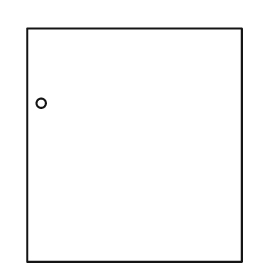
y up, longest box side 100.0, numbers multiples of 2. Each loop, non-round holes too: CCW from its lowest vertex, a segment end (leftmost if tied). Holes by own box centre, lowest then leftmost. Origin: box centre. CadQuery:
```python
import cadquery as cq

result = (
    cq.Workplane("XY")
    .moveTo(-46.0, -50.0)
    .lineTo(46.0, -50.0)
    .lineTo(46.0, 50.0)
    .lineTo(-46.0, 50.0)
    .close()
    .moveTo(-40.0, 18.0)
    .circle(2.0)
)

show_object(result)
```